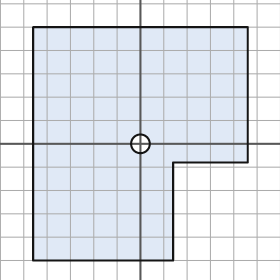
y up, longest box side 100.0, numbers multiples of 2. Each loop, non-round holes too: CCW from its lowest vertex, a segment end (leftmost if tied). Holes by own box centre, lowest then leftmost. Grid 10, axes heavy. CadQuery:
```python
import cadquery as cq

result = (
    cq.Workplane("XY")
    .moveTo(-46.0, -50.0)
    .lineTo(14.0, -50.0)
    .lineTo(14.0, -8.0)
    .lineTo(46.0, -8.0)
    .lineTo(46.0, 50.0)
    .lineTo(-46.0, 50.0)
    .close()
    .moveTo(0.0, 0.0)
    .circle(4.0)
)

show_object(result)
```